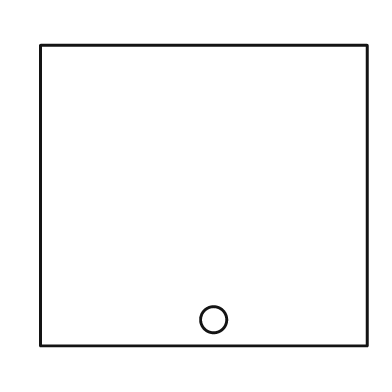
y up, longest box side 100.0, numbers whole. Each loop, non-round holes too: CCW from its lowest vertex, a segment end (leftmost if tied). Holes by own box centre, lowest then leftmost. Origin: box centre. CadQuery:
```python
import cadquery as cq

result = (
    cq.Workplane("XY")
    .moveTo(-50.0, -46.0)
    .lineTo(50.0, -46.0)
    .lineTo(50.0, 46.0)
    .lineTo(-50.0, 46.0)
    .close()
    .moveTo(3.0, -38.0)
    .circle(4.0)
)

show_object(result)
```